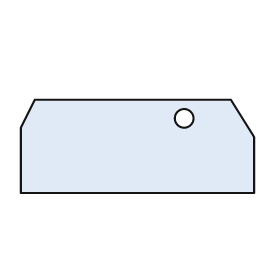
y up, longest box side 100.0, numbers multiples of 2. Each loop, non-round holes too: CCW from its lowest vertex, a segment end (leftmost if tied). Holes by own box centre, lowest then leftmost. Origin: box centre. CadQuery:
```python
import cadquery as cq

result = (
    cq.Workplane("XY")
    .moveTo(-50.0, -20.0)
    .lineTo(50.0, -20.0)
    .lineTo(50.0, 4.0)
    .lineTo(40.0, 20.0)
    .lineTo(-44.0, 20.0)
    .lineTo(-50.0, 8.0)
    .close()
    .moveTo(20.0, 12.0)
    .circle(4.0)
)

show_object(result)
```